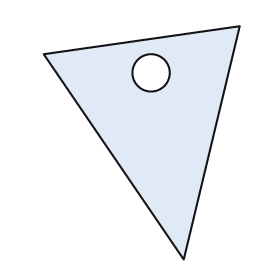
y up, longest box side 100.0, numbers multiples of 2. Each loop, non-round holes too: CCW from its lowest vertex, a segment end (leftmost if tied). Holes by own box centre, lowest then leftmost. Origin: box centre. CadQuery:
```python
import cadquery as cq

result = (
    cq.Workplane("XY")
    .moveTo(18.0, -50.0)
    .lineTo(42.0, 50.0)
    .lineTo(-42.0, 38.0)
    .close()
    .moveTo(4.0, 30.0)
    .circle(8.0)
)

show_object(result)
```